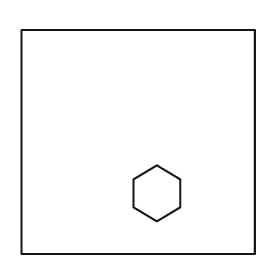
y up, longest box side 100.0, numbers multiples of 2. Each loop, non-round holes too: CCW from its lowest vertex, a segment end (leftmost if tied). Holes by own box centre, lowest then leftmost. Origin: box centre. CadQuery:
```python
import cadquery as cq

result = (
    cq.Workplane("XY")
    .moveTo(-50.0, -48.0)
    .lineTo(50.0, -48.0)
    .lineTo(50.0, 48.0)
    .lineTo(-50.0, 48.0)
    .close()
    .moveTo(8.0, -34.0)
    .lineTo(18.0, -28.0)
    .lineTo(18.0, -16.0)
    .lineTo(8.0, -10.0)
    .lineTo(-2.0, -16.0)
    .lineTo(-2.0, -28.0)
    .close()
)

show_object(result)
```